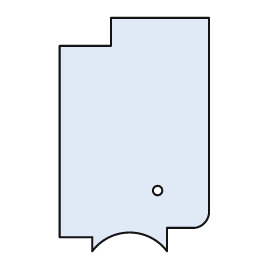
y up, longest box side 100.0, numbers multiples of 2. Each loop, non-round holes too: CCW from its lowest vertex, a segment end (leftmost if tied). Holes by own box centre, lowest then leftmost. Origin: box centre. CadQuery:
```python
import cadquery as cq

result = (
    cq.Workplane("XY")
    .moveTo(-18.0, -50.0)
    .threePointArc((-2.0, -42.0), (14.0, -50.0))
    .lineTo(14.0, -40.0)
    .lineTo(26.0, -40.0)
    .threePointArc((30.0, -38.0), (32.0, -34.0))
    .lineTo(32.0, 50.0)
    .lineTo(-10.0, 50.0)
    .lineTo(-10.0, 38.0)
    .lineTo(-32.0, 38.0)
    .lineTo(-32.0, -44.0)
    .lineTo(-18.0, -44.0)
    .close()
    .moveTo(10.0, -24.0)
    .circle(2.0)
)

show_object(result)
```